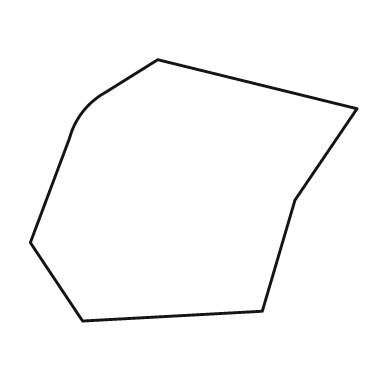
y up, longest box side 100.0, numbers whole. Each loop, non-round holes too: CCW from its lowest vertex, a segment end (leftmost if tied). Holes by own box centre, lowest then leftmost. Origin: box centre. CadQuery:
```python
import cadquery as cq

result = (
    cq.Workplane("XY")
    .moveTo(-34.0, -40.0)
    .lineTo(21.0, -37.0)
    .lineTo(31.0, -3.0)
    .lineTo(50.0, 25.0)
    .lineTo(-11.0, 40.0)
    .lineTo(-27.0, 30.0)
    .threePointArc((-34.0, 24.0), (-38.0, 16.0))
    .lineTo(-50.0, -16.0)
    .close()
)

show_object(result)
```